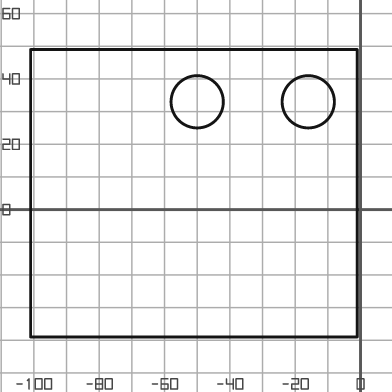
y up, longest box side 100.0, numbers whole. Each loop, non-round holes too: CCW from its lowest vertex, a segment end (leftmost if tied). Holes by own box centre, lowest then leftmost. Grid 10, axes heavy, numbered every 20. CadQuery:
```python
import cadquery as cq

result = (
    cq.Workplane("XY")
    .moveTo(-101.0, -39.0)
    .lineTo(-1.0, -39.0)
    .lineTo(-1.0, 49.0)
    .lineTo(-101.0, 49.0)
    .close()
    .moveTo(-50.0, 33.0)
    .circle(8.0)
    .moveTo(-16.0, 33.0)
    .circle(8.0)
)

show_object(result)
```